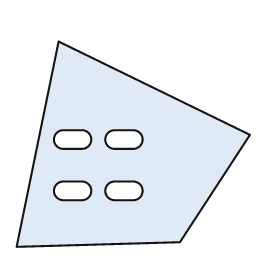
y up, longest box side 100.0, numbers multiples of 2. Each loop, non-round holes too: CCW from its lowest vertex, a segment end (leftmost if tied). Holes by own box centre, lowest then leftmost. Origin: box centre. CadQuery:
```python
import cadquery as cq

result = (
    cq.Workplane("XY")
    .moveTo(-50.0, -44.0)
    .lineTo(20.0, -42.0)
    .lineTo(50.0, 4.0)
    .lineTo(-32.0, 44.0)
    .close()
    .moveTo(-30.0, -24.0)
    .lineTo(-22.0, -24.0)
    .threePointArc((-18.0, -20.0), (-22.0, -16.0))
    .lineTo(-30.0, -16.0)
    .threePointArc((-34.0, -20.0), (-30.0, -24.0))
    .close()
    .moveTo(-8.0, -24.0)
    .lineTo(0.0, -24.0)
    .threePointArc((4.0, -20.0), (0.0, -16.0))
    .lineTo(-8.0, -16.0)
    .threePointArc((-12.0, -20.0), (-8.0, -24.0))
    .close()
    .moveTo(-30.0, -2.0)
    .lineTo(-22.0, -2.0)
    .threePointArc((-18.0, 2.0), (-22.0, 6.0))
    .lineTo(-30.0, 6.0)
    .threePointArc((-34.0, 2.0), (-30.0, -2.0))
    .close()
    .moveTo(-8.0, -2.0)
    .lineTo(0.0, -2.0)
    .threePointArc((4.0, 2.0), (0.0, 6.0))
    .lineTo(-8.0, 6.0)
    .threePointArc((-12.0, 2.0), (-8.0, -2.0))
    .close()
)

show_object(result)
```